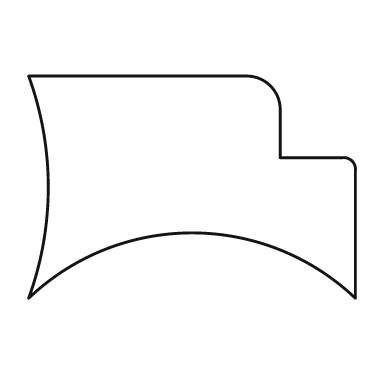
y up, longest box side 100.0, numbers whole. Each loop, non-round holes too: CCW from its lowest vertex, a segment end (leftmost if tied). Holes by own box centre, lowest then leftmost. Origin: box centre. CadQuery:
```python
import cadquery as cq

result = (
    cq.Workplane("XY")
    .moveTo(-50.0, -34.0)
    .threePointArc((0.0, -14.0), (50.0, -34.0))
    .lineTo(50.0, 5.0)
    .threePointArc((49.0, 8.0), (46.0, 9.0))
    .lineTo(27.0, 9.0)
    .lineTo(27.0, 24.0)
    .threePointArc((24.0, 31.0), (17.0, 34.0))
    .lineTo(-50.0, 34.0)
    .threePointArc((-44.0, 0.0), (-50.0, -34.0))
    .close()
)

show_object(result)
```